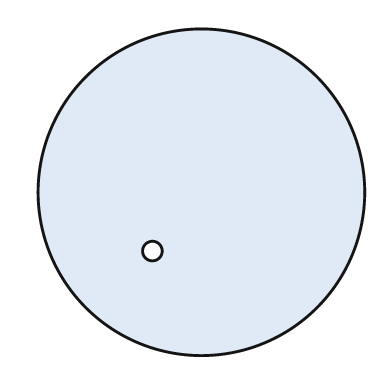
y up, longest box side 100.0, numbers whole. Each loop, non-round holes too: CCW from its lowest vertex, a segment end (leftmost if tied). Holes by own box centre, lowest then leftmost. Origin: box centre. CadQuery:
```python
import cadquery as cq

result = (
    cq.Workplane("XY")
    .moveTo(0.0, 0.0)
    .circle(50.0)
    .moveTo(-15.0, -18.0)
    .circle(3.0)
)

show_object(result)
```